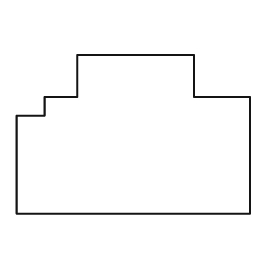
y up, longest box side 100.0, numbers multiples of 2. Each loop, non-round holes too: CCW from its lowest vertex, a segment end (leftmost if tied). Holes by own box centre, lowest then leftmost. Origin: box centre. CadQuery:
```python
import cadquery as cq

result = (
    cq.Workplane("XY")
    .moveTo(-50.0, -34.0)
    .lineTo(50.0, -34.0)
    .lineTo(50.0, 16.0)
    .lineTo(26.0, 16.0)
    .lineTo(26.0, 34.0)
    .lineTo(-24.0, 34.0)
    .lineTo(-24.0, 16.0)
    .lineTo(-38.0, 16.0)
    .lineTo(-38.0, 8.0)
    .lineTo(-50.0, 8.0)
    .close()
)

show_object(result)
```